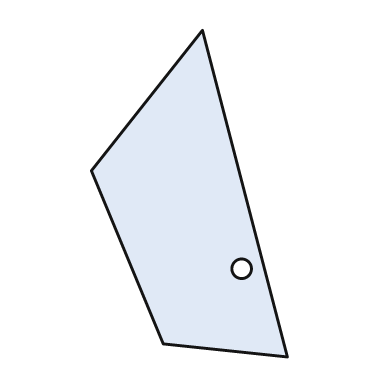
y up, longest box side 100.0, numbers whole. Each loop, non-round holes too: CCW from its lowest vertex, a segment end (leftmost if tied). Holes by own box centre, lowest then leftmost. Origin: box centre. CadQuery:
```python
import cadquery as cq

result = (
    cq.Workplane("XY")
    .moveTo(30.0, -50.0)
    .lineTo(4.0, 50.0)
    .lineTo(-30.0, 7.0)
    .lineTo(-8.0, -46.0)
    .close()
    .moveTo(16.0, -23.0)
    .circle(3.0)
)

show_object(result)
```